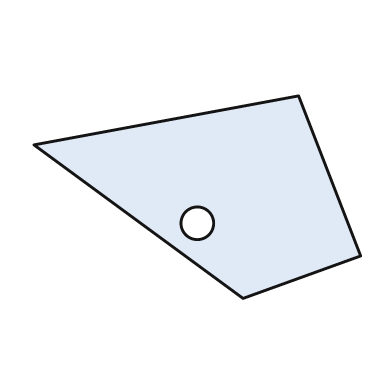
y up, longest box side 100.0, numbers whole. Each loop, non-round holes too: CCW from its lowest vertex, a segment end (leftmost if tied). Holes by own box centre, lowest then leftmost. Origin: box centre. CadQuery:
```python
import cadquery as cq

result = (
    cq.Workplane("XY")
    .moveTo(14.0, -31.0)
    .lineTo(50.0, -18.0)
    .lineTo(31.0, 31.0)
    .lineTo(-50.0, 16.0)
    .close()
    .moveTo(0.0, -8.0)
    .circle(5.0)
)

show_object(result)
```